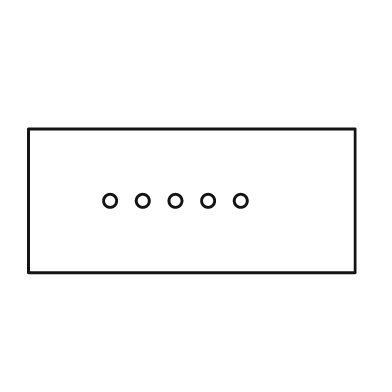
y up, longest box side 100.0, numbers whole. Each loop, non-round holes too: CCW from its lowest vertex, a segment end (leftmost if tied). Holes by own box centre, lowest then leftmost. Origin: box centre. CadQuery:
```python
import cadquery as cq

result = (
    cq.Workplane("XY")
    .moveTo(-50.0, -22.0)
    .lineTo(50.0, -22.0)
    .lineTo(50.0, 22.0)
    .lineTo(-50.0, 22.0)
    .close()
    .moveTo(-25.0, 0.0)
    .circle(2.0)
    .moveTo(-15.0, 0.0)
    .circle(2.0)
    .moveTo(-5.0, 0.0)
    .circle(2.0)
    .moveTo(5.0, 0.0)
    .circle(2.0)
    .moveTo(15.0, 0.0)
    .circle(2.0)
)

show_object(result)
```